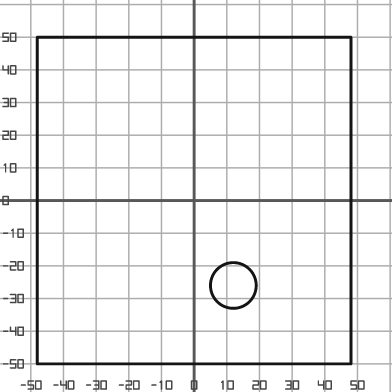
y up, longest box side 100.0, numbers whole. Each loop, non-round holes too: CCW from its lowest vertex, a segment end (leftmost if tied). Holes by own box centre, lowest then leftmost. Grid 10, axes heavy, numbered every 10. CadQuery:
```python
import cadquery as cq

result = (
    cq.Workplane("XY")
    .moveTo(-48.0, -50.0)
    .lineTo(48.0, -50.0)
    .lineTo(48.0, 50.0)
    .lineTo(-48.0, 50.0)
    .close()
    .moveTo(12.0, -26.0)
    .circle(7.0)
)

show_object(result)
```